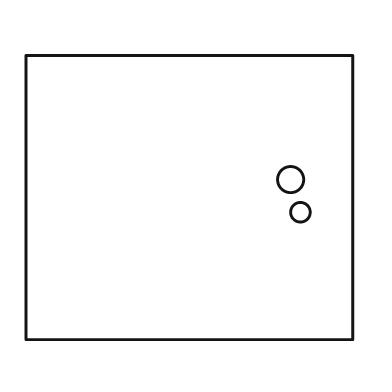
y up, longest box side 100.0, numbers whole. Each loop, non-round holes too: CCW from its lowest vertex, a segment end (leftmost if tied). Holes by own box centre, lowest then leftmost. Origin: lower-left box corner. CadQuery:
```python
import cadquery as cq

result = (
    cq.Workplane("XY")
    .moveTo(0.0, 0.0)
    .lineTo(100.0, 0.0)
    .lineTo(100.0, 87.0)
    .lineTo(0.0, 87.0)
    .close()
    .moveTo(84.0, 39.0)
    .circle(3.0)
    .moveTo(81.0, 49.0)
    .circle(4.0)
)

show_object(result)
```